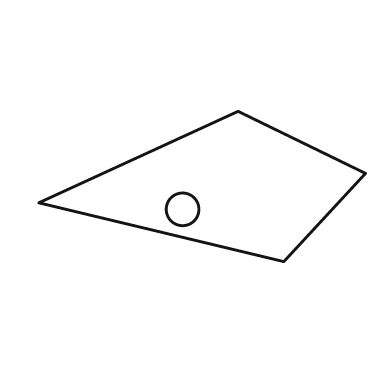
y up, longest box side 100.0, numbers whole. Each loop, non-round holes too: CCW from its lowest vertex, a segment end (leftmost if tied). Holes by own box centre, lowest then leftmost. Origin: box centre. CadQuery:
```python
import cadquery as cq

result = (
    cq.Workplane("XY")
    .moveTo(25.0, -23.0)
    .lineTo(50.0, 4.0)
    .lineTo(11.0, 23.0)
    .lineTo(-50.0, -5.0)
    .close()
    .moveTo(-6.0, -7.0)
    .circle(5.0)
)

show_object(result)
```